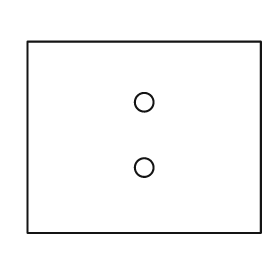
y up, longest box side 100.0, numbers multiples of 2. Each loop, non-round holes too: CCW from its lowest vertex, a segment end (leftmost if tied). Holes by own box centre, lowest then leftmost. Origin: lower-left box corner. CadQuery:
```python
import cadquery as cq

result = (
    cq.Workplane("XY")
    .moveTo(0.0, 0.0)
    .lineTo(100.0, 0.0)
    .lineTo(100.0, 82.0)
    .lineTo(0.0, 82.0)
    .close()
    .moveTo(50.0, 28.0)
    .circle(4.0)
    .moveTo(50.0, 56.0)
    .circle(4.0)
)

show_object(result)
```